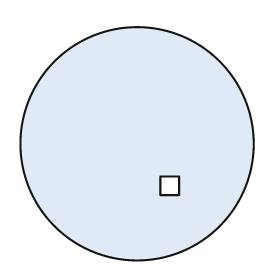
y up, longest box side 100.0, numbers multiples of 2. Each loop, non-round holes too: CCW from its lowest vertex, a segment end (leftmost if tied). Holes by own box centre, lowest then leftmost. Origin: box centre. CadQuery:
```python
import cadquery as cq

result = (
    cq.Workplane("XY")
    .moveTo(0.0, 0.0)
    .circle(50.0)
    .moveTo(10.0, -22.0)
    .lineTo(18.0, -22.0)
    .lineTo(18.0, -14.0)
    .lineTo(10.0, -14.0)
    .close()
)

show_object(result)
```